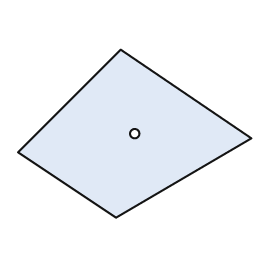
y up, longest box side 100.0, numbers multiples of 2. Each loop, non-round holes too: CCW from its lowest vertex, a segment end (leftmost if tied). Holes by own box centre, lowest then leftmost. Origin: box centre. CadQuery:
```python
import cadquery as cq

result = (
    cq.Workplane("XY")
    .moveTo(-8.0, -36.0)
    .lineTo(50.0, -2.0)
    .lineTo(-6.0, 36.0)
    .lineTo(-50.0, -8.0)
    .close()
    .moveTo(0.0, 0.0)
    .circle(2.0)
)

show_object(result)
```